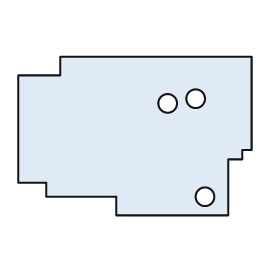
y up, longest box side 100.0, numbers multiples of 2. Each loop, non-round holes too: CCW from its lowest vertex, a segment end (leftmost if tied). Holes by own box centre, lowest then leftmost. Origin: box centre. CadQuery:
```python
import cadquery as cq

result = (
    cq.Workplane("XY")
    .moveTo(-8.0, -34.0)
    .lineTo(40.0, -34.0)
    .lineTo(40.0, -10.0)
    .lineTo(46.0, -10.0)
    .lineTo(46.0, -6.0)
    .lineTo(50.0, -6.0)
    .lineTo(50.0, 34.0)
    .lineTo(-32.0, 34.0)
    .lineTo(-32.0, 26.0)
    .lineTo(-50.0, 26.0)
    .lineTo(-50.0, -20.0)
    .lineTo(-38.0, -20.0)
    .lineTo(-38.0, -26.0)
    .lineTo(-8.0, -26.0)
    .close()
    .moveTo(30.0, -26.0)
    .circle(4.0)
    .moveTo(14.0, 14.0)
    .circle(4.0)
    .moveTo(26.0, 16.0)
    .circle(4.0)
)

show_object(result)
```